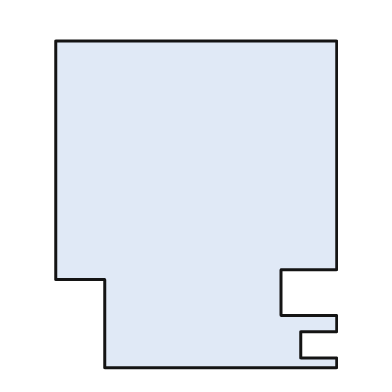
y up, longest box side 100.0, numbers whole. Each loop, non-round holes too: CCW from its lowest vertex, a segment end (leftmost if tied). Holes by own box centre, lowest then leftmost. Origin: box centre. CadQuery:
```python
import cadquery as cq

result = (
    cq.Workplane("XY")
    .moveTo(-28.0, -50.0)
    .lineTo(43.0, -50.0)
    .lineTo(43.0, -47.0)
    .lineTo(32.0, -47.0)
    .lineTo(32.0, -39.0)
    .lineTo(43.0, -39.0)
    .lineTo(43.0, -34.0)
    .lineTo(26.0, -34.0)
    .lineTo(26.0, -20.0)
    .lineTo(43.0, -20.0)
    .lineTo(43.0, 50.0)
    .lineTo(-43.0, 50.0)
    .lineTo(-43.0, -23.0)
    .lineTo(-28.0, -23.0)
    .close()
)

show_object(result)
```